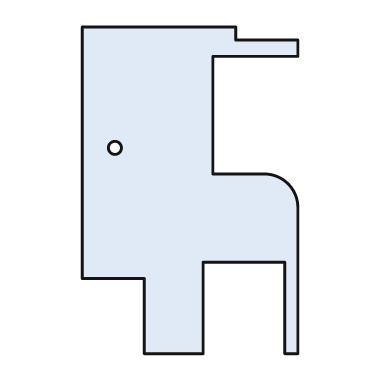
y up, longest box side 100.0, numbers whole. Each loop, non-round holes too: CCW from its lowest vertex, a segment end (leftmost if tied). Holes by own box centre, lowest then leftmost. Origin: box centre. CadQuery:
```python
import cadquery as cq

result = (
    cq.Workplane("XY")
    .moveTo(-14.0, -50.0)
    .lineTo(4.0, -50.0)
    .lineTo(4.0, -22.0)
    .lineTo(29.0, -22.0)
    .lineTo(29.0, -50.0)
    .lineTo(33.0, -50.0)
    .lineTo(33.0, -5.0)
    .threePointArc((30.0, 2.0), (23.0, 5.0))
    .lineTo(7.0, 5.0)
    .lineTo(7.0, 41.0)
    .lineTo(33.0, 41.0)
    .lineTo(33.0, 46.0)
    .lineTo(14.0, 46.0)
    .lineTo(14.0, 50.0)
    .lineTo(-33.0, 50.0)
    .lineTo(-33.0, -27.0)
    .lineTo(-14.0, -27.0)
    .close()
    .moveTo(-23.0, 13.0)
    .circle(2.0)
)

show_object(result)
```